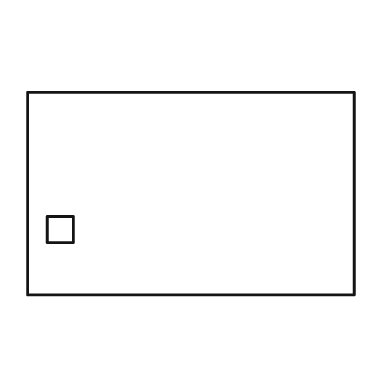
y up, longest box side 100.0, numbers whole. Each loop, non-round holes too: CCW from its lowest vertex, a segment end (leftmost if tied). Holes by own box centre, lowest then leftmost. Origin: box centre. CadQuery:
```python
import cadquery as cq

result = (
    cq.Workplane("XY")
    .moveTo(-50.0, -31.0)
    .lineTo(50.0, -31.0)
    .lineTo(50.0, 31.0)
    .lineTo(-50.0, 31.0)
    .close()
    .moveTo(-44.0, -15.0)
    .lineTo(-36.0, -15.0)
    .lineTo(-36.0, -7.0)
    .lineTo(-44.0, -7.0)
    .close()
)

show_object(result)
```